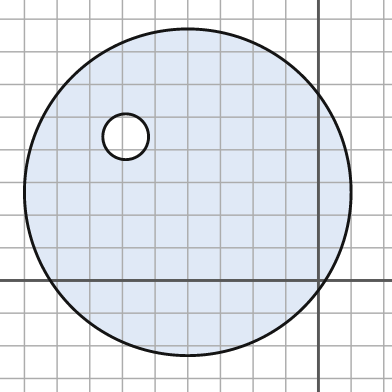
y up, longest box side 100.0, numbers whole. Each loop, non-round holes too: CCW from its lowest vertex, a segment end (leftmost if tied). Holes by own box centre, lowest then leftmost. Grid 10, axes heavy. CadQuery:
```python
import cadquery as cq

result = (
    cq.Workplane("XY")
    .moveTo(-40.0, 27.0)
    .circle(50.0)
    .moveTo(-59.0, 44.0)
    .circle(7.0)
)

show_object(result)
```